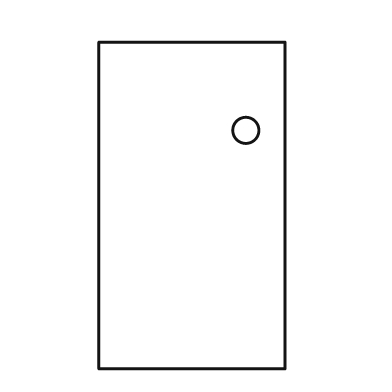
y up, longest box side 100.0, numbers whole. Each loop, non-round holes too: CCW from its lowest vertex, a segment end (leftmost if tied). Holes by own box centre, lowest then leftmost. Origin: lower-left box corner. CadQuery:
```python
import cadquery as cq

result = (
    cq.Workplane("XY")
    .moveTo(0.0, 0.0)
    .lineTo(57.0, 0.0)
    .lineTo(57.0, 100.0)
    .lineTo(0.0, 100.0)
    .close()
    .moveTo(45.0, 73.0)
    .circle(4.0)
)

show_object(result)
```